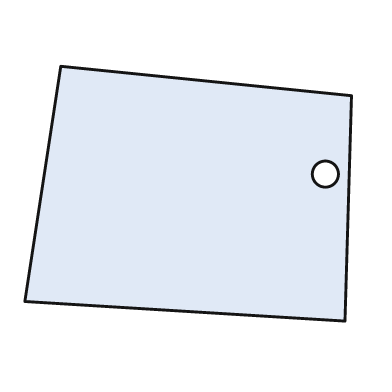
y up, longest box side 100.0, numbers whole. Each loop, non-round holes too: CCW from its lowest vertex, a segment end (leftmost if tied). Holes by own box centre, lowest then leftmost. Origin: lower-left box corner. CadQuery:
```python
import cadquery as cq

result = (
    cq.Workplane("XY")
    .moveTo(98.0, 0.0)
    .lineTo(100.0, 69.0)
    .lineTo(11.0, 78.0)
    .lineTo(0.0, 6.0)
    .close()
    .moveTo(92.0, 45.0)
    .circle(4.0)
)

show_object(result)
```